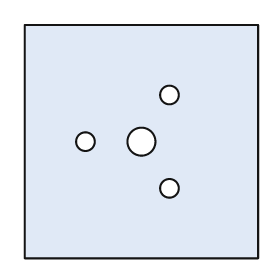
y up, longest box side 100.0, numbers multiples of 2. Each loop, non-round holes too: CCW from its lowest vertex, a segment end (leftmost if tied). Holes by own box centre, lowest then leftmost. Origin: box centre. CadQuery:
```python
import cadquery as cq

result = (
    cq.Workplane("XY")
    .moveTo(-50.0, -50.0)
    .lineTo(50.0, -50.0)
    .lineTo(50.0, 50.0)
    .lineTo(-50.0, 50.0)
    .close()
    .moveTo(12.0, -20.0)
    .circle(4.0)
    .moveTo(-24.0, 0.0)
    .circle(4.0)
    .moveTo(0.0, 0.0)
    .circle(6.0)
    .moveTo(12.0, 20.0)
    .circle(4.0)
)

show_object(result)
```